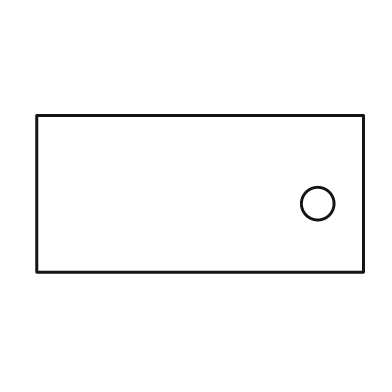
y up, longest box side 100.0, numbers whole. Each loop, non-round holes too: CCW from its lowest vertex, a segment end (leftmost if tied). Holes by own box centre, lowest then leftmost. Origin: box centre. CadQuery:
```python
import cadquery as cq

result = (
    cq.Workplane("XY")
    .moveTo(-50.0, -24.0)
    .lineTo(50.0, -24.0)
    .lineTo(50.0, 24.0)
    .lineTo(-50.0, 24.0)
    .close()
    .moveTo(36.0, -3.0)
    .circle(5.0)
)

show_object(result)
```